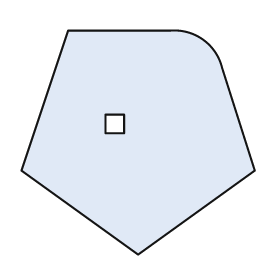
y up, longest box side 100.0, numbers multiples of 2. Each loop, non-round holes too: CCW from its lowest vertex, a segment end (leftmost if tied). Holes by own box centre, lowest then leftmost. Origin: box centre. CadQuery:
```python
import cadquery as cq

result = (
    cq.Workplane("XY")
    .moveTo(0.0, -48.0)
    .lineTo(50.0, -12.0)
    .lineTo(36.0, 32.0)
    .threePointArc((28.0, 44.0), (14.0, 48.0))
    .lineTo(-30.0, 48.0)
    .lineTo(-50.0, -12.0)
    .close()
    .moveTo(-14.0, 4.0)
    .lineTo(-6.0, 4.0)
    .lineTo(-6.0, 12.0)
    .lineTo(-14.0, 12.0)
    .close()
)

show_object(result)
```